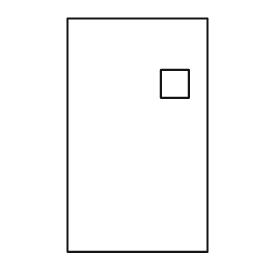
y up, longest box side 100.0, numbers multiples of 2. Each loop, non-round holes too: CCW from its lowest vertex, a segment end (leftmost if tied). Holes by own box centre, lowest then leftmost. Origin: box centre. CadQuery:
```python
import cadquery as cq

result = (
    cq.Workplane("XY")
    .moveTo(-30.0, -50.0)
    .lineTo(30.0, -50.0)
    .lineTo(30.0, 50.0)
    .lineTo(-30.0, 50.0)
    .close()
    .moveTo(10.0, 16.0)
    .lineTo(22.0, 16.0)
    .lineTo(22.0, 28.0)
    .lineTo(10.0, 28.0)
    .close()
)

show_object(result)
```